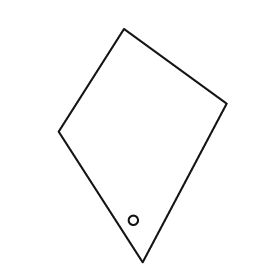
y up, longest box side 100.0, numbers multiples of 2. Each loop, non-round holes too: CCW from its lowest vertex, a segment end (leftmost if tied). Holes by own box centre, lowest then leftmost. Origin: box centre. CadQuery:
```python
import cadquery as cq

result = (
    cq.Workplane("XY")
    .moveTo(0.0, -50.0)
    .lineTo(36.0, 18.0)
    .lineTo(-8.0, 50.0)
    .lineTo(-36.0, 6.0)
    .close()
    .moveTo(-4.0, -32.0)
    .circle(2.0)
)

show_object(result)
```